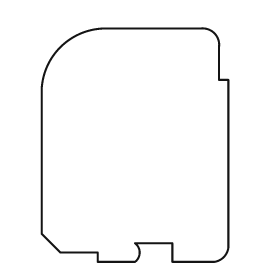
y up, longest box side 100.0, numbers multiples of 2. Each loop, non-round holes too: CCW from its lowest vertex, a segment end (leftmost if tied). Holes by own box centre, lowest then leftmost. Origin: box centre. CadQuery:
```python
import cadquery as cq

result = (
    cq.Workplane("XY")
    .moveTo(-16.0, -50.0)
    .lineTo(0.0, -50.0)
    .threePointArc((2.0, -46.0), (0.0, -42.0))
    .lineTo(16.0, -42.0)
    .lineTo(16.0, -50.0)
    .lineTo(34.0, -50.0)
    .threePointArc((38.0, -48.0), (40.0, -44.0))
    .lineTo(40.0, 28.0)
    .lineTo(36.0, 28.0)
    .lineTo(36.0, 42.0)
    .threePointArc((34.0, 48.0), (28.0, 50.0))
    .lineTo(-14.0, 50.0)
    .threePointArc((-32.0, 42.0), (-40.0, 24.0))
    .lineTo(-40.0, -38.0)
    .lineTo(-32.0, -46.0)
    .lineTo(-16.0, -46.0)
    .close()
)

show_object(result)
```